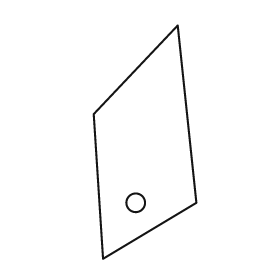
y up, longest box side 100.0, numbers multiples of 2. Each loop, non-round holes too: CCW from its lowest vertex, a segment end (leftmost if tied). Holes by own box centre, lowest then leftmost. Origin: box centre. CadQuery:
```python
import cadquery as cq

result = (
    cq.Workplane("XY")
    .moveTo(-18.0, -50.0)
    .lineTo(22.0, -26.0)
    .lineTo(14.0, 50.0)
    .lineTo(-22.0, 12.0)
    .close()
    .moveTo(-4.0, -26.0)
    .circle(4.0)
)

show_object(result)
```